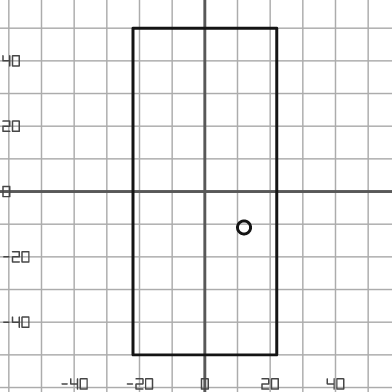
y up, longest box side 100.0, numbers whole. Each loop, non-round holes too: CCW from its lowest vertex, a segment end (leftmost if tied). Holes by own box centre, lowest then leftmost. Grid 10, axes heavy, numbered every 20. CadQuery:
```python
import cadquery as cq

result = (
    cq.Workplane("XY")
    .moveTo(-22.0, -50.0)
    .lineTo(22.0, -50.0)
    .lineTo(22.0, 50.0)
    .lineTo(-22.0, 50.0)
    .close()
    .moveTo(12.0, -11.0)
    .circle(2.0)
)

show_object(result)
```